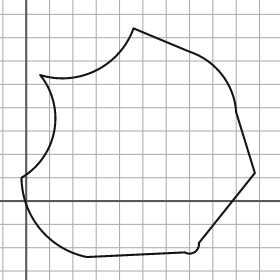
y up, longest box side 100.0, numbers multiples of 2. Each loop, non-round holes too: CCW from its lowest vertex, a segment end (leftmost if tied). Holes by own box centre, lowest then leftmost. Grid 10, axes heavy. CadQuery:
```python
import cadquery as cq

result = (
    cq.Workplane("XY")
    .moveTo(26.0, -24.0)
    .lineTo(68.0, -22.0)
    .threePointArc((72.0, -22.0), (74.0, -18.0))
    .lineTo(98.0, 12.0)
    .lineTo(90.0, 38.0)
    .threePointArc((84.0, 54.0), (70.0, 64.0))
    .lineTo(46.0, 74.0)
    .threePointArc((30.0, 56.0), (6.0, 54.0))
    .threePointArc((12.0, 30.0), (-2.0, 10.0))
    .threePointArc((6.0, -12.0), (26.0, -24.0))
    .close()
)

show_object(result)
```